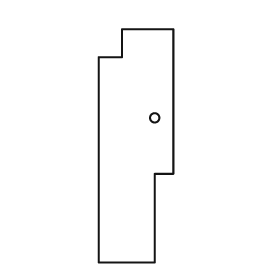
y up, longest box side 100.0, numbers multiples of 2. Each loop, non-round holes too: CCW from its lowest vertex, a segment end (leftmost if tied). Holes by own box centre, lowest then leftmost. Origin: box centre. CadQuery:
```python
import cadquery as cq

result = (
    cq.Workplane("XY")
    .moveTo(-16.0, -50.0)
    .lineTo(8.0, -50.0)
    .lineTo(8.0, -12.0)
    .lineTo(16.0, -12.0)
    .lineTo(16.0, 50.0)
    .lineTo(-6.0, 50.0)
    .lineTo(-6.0, 38.0)
    .lineTo(-16.0, 38.0)
    .close()
    .moveTo(8.0, 12.0)
    .circle(2.0)
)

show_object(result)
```